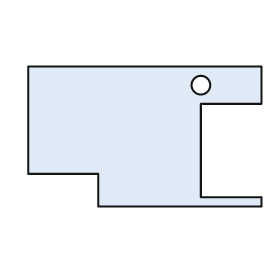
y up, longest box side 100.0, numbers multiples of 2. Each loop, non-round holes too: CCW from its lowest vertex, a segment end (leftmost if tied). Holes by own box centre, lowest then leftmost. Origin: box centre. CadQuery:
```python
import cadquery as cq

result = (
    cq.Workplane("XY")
    .moveTo(-20.0, -30.0)
    .lineTo(50.0, -30.0)
    .lineTo(50.0, -26.0)
    .lineTo(24.0, -26.0)
    .lineTo(24.0, 14.0)
    .lineTo(50.0, 14.0)
    .lineTo(50.0, 30.0)
    .lineTo(-50.0, 30.0)
    .lineTo(-50.0, -16.0)
    .lineTo(-20.0, -16.0)
    .close()
    .moveTo(24.0, 22.0)
    .circle(4.0)
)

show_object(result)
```